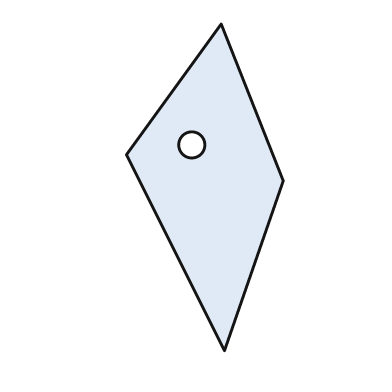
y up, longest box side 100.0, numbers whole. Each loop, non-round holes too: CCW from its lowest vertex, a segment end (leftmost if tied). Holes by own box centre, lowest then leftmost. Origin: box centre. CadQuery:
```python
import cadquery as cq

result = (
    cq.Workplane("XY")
    .moveTo(6.0, -50.0)
    .lineTo(24.0, 2.0)
    .lineTo(5.0, 50.0)
    .lineTo(-24.0, 10.0)
    .close()
    .moveTo(-4.0, 13.0)
    .circle(4.0)
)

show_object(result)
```